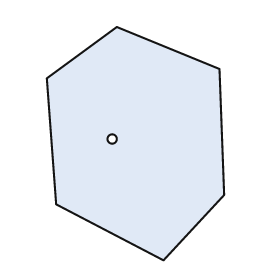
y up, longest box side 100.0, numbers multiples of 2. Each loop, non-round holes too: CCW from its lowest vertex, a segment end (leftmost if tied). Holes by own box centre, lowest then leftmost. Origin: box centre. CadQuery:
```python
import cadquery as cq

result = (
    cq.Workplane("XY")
    .moveTo(12.0, -50.0)
    .lineTo(38.0, -22.0)
    .lineTo(36.0, 32.0)
    .lineTo(-8.0, 50.0)
    .lineTo(-38.0, 28.0)
    .lineTo(-34.0, -26.0)
    .close()
    .moveTo(-10.0, 2.0)
    .circle(2.0)
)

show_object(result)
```